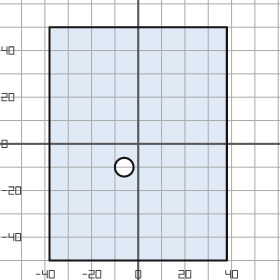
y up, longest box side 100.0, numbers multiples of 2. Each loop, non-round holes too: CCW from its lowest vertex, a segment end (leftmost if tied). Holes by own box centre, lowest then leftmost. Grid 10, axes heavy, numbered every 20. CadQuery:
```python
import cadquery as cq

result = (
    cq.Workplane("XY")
    .moveTo(-38.0, -50.0)
    .lineTo(38.0, -50.0)
    .lineTo(38.0, 50.0)
    .lineTo(-38.0, 50.0)
    .close()
    .moveTo(-6.0, -10.0)
    .circle(4.0)
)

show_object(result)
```